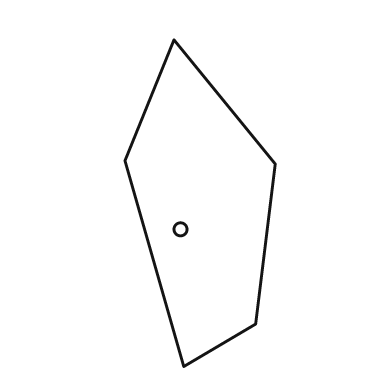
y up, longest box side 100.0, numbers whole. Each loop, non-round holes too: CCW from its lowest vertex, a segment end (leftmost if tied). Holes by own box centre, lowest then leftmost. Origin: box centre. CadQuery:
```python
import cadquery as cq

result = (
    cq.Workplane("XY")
    .moveTo(-5.0, -50.0)
    .lineTo(17.0, -37.0)
    .lineTo(23.0, 12.0)
    .lineTo(-8.0, 50.0)
    .lineTo(-23.0, 13.0)
    .close()
    .moveTo(-6.0, -8.0)
    .circle(2.0)
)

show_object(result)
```